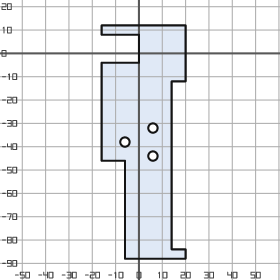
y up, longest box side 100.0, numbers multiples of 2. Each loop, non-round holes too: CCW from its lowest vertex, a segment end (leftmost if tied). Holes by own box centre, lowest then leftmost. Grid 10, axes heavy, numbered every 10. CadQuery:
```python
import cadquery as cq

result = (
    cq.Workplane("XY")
    .moveTo(-6.0, -88.0)
    .lineTo(20.0, -88.0)
    .lineTo(20.0, -84.0)
    .lineTo(14.0, -84.0)
    .lineTo(14.0, -12.0)
    .lineTo(20.0, -12.0)
    .lineTo(20.0, 12.0)
    .lineTo(-16.0, 12.0)
    .lineTo(-16.0, 8.0)
    .lineTo(0.0, 8.0)
    .lineTo(0.0, -4.0)
    .lineTo(-16.0, -4.0)
    .lineTo(-16.0, -46.0)
    .lineTo(-6.0, -46.0)
    .close()
    .moveTo(6.0, -44.0)
    .circle(2.0)
    .moveTo(-6.0, -38.0)
    .circle(2.0)
    .moveTo(6.0, -32.0)
    .circle(2.0)
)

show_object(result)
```